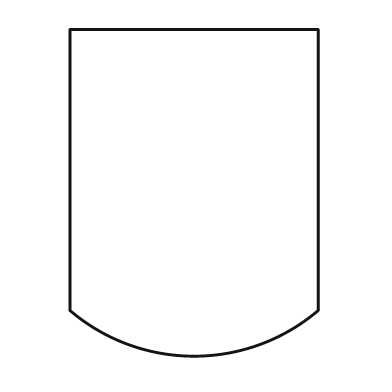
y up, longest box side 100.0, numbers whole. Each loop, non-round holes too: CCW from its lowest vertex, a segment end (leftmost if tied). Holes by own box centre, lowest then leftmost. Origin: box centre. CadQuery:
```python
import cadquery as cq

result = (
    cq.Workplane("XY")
    .moveTo(-38.0, -36.0)
    .threePointArc((0.0, -50.0), (38.0, -36.0))
    .lineTo(38.0, 50.0)
    .lineTo(-38.0, 50.0)
    .close()
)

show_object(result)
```